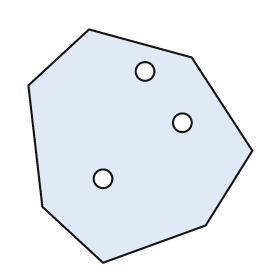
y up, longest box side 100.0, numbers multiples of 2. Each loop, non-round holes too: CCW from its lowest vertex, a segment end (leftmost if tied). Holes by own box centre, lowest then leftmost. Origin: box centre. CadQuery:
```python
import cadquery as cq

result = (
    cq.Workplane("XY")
    .moveTo(-16.0, -50.0)
    .lineTo(28.0, -34.0)
    .lineTo(48.0, -2.0)
    .lineTo(22.0, 38.0)
    .lineTo(-22.0, 50.0)
    .lineTo(-48.0, 26.0)
    .lineTo(-42.0, -26.0)
    .close()
    .moveTo(-16.0, -14.0)
    .circle(4.0)
    .moveTo(18.0, 10.0)
    .circle(4.0)
    .moveTo(2.0, 32.0)
    .circle(4.0)
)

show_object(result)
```